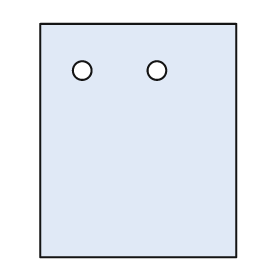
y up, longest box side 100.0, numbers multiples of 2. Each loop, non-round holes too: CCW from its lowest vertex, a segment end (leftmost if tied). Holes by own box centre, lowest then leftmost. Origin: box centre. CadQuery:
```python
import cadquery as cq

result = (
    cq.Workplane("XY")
    .moveTo(-42.0, -50.0)
    .lineTo(42.0, -50.0)
    .lineTo(42.0, 50.0)
    .lineTo(-42.0, 50.0)
    .close()
    .moveTo(-24.0, 30.0)
    .circle(4.0)
    .moveTo(8.0, 30.0)
    .circle(4.0)
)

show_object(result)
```